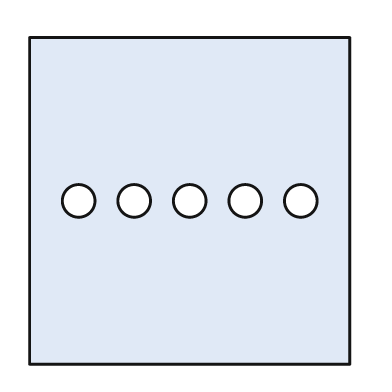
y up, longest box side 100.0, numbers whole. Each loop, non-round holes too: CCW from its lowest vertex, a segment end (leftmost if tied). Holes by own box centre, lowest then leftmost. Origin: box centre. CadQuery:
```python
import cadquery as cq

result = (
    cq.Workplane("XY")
    .moveTo(-49.0, -50.0)
    .lineTo(49.0, -50.0)
    .lineTo(49.0, 50.0)
    .lineTo(-49.0, 50.0)
    .close()
    .moveTo(-34.0, 0.0)
    .circle(5.0)
    .moveTo(-17.0, 0.0)
    .circle(5.0)
    .moveTo(0.0, 0.0)
    .circle(5.0)
    .moveTo(17.0, 0.0)
    .circle(5.0)
    .moveTo(34.0, 0.0)
    .circle(5.0)
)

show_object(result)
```